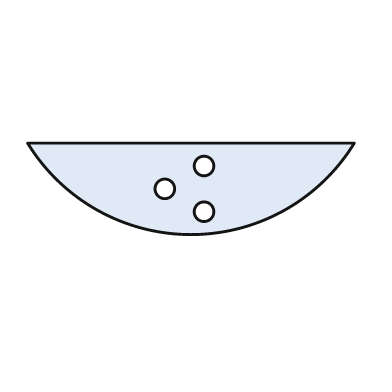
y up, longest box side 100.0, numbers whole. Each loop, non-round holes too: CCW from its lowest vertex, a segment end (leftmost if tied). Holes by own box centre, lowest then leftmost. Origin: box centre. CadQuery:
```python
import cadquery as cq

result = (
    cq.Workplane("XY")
    .moveTo(-50.0, 14.0)
    .threePointArc((0.0, -14.0), (50.0, 14.0))
    .close()
    .moveTo(4.0, -7.0)
    .circle(3.0)
    .moveTo(-8.0, 0.0)
    .circle(3.0)
    .moveTo(4.0, 7.0)
    .circle(3.0)
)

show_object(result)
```